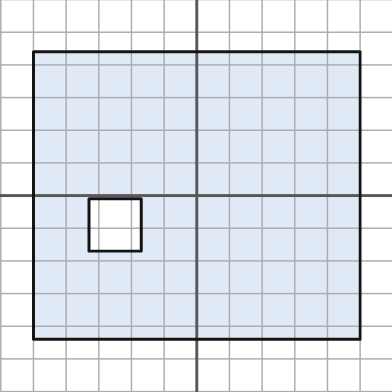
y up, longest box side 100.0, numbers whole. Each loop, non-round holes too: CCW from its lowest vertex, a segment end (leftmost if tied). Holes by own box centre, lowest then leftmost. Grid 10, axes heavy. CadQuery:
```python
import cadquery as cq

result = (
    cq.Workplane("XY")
    .moveTo(-50.0, -44.0)
    .lineTo(50.0, -44.0)
    .lineTo(50.0, 44.0)
    .lineTo(-50.0, 44.0)
    .close()
    .moveTo(-33.0, -17.0)
    .lineTo(-17.0, -17.0)
    .lineTo(-17.0, -1.0)
    .lineTo(-33.0, -1.0)
    .close()
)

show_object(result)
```